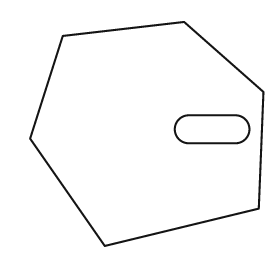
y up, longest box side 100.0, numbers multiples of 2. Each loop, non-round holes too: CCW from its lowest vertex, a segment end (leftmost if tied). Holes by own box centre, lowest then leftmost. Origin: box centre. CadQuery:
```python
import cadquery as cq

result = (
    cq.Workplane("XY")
    .moveTo(-18.0, -48.0)
    .lineTo(48.0, -32.0)
    .lineTo(50.0, 18.0)
    .lineTo(16.0, 48.0)
    .lineTo(-36.0, 42.0)
    .lineTo(-50.0, -2.0)
    .close()
    .moveTo(18.0, -4.0)
    .lineTo(38.0, -4.0)
    .threePointArc((44.0, 2.0), (38.0, 8.0))
    .lineTo(18.0, 8.0)
    .threePointArc((12.0, 2.0), (18.0, -4.0))
    .close()
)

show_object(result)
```